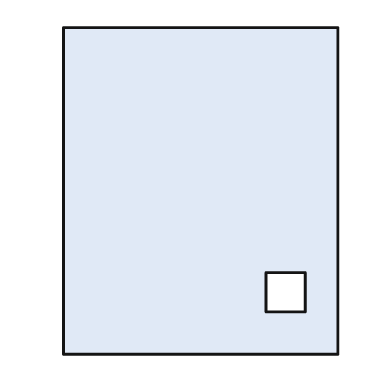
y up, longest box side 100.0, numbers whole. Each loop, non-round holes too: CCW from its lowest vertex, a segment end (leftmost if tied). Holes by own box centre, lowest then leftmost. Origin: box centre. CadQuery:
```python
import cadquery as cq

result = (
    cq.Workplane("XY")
    .moveTo(-42.0, -50.0)
    .lineTo(42.0, -50.0)
    .lineTo(42.0, 50.0)
    .lineTo(-42.0, 50.0)
    .close()
    .moveTo(20.0, -37.0)
    .lineTo(32.0, -37.0)
    .lineTo(32.0, -25.0)
    .lineTo(20.0, -25.0)
    .close()
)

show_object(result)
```